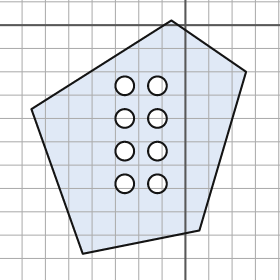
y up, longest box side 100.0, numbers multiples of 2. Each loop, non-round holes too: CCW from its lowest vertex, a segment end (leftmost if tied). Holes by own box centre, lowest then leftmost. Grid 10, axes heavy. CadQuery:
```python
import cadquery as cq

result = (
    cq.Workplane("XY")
    .moveTo(-44.0, -98.0)
    .lineTo(6.0, -88.0)
    .lineTo(26.0, -20.0)
    .lineTo(-6.0, 2.0)
    .lineTo(-66.0, -36.0)
    .close()
    .moveTo(-26.0, -68.0)
    .circle(4.0)
    .moveTo(-12.0, -68.0)
    .circle(4.0)
    .moveTo(-26.0, -54.0)
    .circle(4.0)
    .moveTo(-12.0, -54.0)
    .circle(4.0)
    .moveTo(-26.0, -40.0)
    .circle(4.0)
    .moveTo(-12.0, -40.0)
    .circle(4.0)
    .moveTo(-26.0, -26.0)
    .circle(4.0)
    .moveTo(-12.0, -26.0)
    .circle(4.0)
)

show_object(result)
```